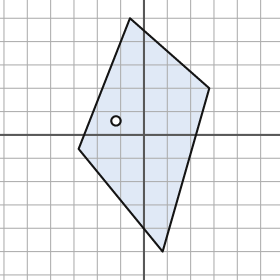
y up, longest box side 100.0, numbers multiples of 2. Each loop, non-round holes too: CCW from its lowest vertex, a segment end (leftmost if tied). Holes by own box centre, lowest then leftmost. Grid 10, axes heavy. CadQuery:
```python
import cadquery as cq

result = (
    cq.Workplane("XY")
    .moveTo(8.0, -50.0)
    .lineTo(28.0, 20.0)
    .lineTo(-6.0, 50.0)
    .lineTo(-28.0, -6.0)
    .close()
    .moveTo(-12.0, 6.0)
    .circle(2.0)
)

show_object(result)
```